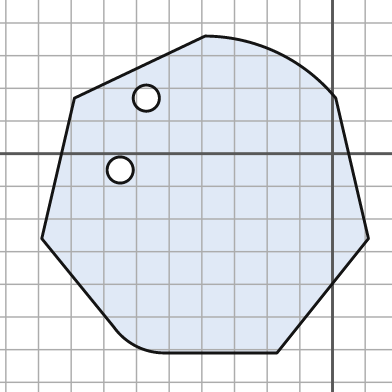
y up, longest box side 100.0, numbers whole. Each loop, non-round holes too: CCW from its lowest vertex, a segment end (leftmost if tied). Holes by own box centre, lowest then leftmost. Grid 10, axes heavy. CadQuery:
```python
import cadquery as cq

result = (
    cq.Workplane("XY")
    .moveTo(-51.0, -61.0)
    .lineTo(-17.0, -61.0)
    .lineTo(11.0, -26.0)
    .lineTo(1.0, 17.0)
    .threePointArc((-17.0, 31.0), (-39.0, 36.0))
    .lineTo(-79.0, 17.0)
    .lineTo(-89.0, -26.0)
    .lineTo(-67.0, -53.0)
    .threePointArc((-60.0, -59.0), (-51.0, -61.0))
    .close()
    .moveTo(-65.0, -5.0)
    .circle(4.0)
    .moveTo(-57.0, 17.0)
    .circle(4.0)
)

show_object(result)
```